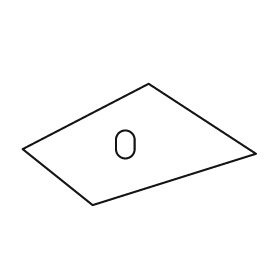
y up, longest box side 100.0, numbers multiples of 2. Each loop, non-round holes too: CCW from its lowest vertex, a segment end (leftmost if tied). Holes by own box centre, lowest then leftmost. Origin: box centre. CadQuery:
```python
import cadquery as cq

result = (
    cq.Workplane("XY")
    .moveTo(-20.0, -26.0)
    .lineTo(50.0, -4.0)
    .lineTo(4.0, 26.0)
    .lineTo(-50.0, -2.0)
    .close()
    .moveTo(-10.0, -2.0)
    .threePointArc((-6.0, -6.0), (-2.0, -2.0))
    .lineTo(-2.0, 2.0)
    .threePointArc((-6.0, 6.0), (-10.0, 2.0))
    .close()
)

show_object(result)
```